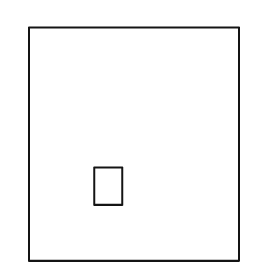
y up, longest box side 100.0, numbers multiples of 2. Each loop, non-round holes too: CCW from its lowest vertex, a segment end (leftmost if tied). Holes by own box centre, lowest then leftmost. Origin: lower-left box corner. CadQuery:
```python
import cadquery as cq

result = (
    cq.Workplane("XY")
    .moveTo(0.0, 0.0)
    .lineTo(90.0, 0.0)
    .lineTo(90.0, 100.0)
    .lineTo(0.0, 100.0)
    .close()
    .moveTo(28.0, 24.0)
    .lineTo(40.0, 24.0)
    .lineTo(40.0, 40.0)
    .lineTo(28.0, 40.0)
    .close()
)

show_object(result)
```